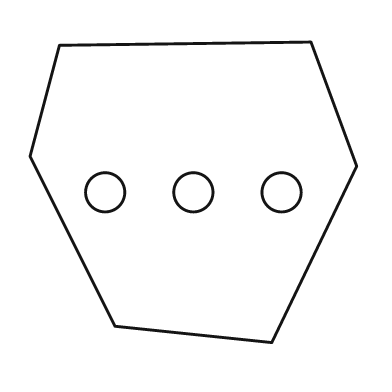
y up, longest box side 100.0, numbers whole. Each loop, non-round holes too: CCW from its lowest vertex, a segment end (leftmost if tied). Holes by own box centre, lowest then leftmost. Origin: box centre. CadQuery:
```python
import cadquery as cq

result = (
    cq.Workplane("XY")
    .moveTo(24.0, -46.0)
    .lineTo(50.0, 8.0)
    .lineTo(36.0, 46.0)
    .lineTo(-41.0, 45.0)
    .lineTo(-50.0, 11.0)
    .lineTo(-24.0, -41.0)
    .close()
    .moveTo(-27.0, 0.0)
    .circle(6.0)
    .moveTo(0.0, 0.0)
    .circle(6.0)
    .moveTo(27.0, 0.0)
    .circle(6.0)
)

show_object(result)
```